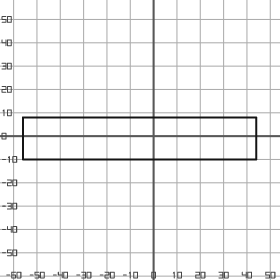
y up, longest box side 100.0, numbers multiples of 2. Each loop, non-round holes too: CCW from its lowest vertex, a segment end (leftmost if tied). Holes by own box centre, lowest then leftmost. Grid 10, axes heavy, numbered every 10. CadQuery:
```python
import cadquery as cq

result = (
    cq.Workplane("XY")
    .moveTo(-56.0, -10.0)
    .lineTo(44.0, -10.0)
    .lineTo(44.0, 8.0)
    .lineTo(-56.0, 8.0)
    .close()
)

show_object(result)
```